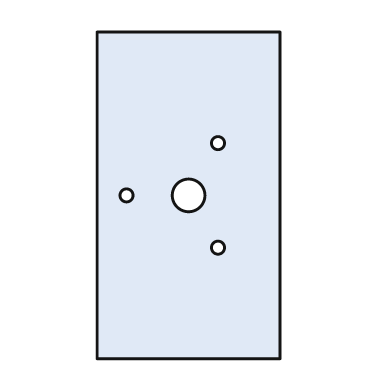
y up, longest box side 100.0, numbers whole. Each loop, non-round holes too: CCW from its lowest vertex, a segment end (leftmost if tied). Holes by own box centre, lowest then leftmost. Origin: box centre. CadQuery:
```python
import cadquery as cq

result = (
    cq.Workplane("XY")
    .moveTo(-28.0, -50.0)
    .lineTo(28.0, -50.0)
    .lineTo(28.0, 50.0)
    .lineTo(-28.0, 50.0)
    .close()
    .moveTo(9.0, -16.0)
    .circle(2.0)
    .moveTo(-19.0, 0.0)
    .circle(2.0)
    .moveTo(0.0, 0.0)
    .circle(5.0)
    .moveTo(9.0, 16.0)
    .circle(2.0)
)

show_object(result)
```